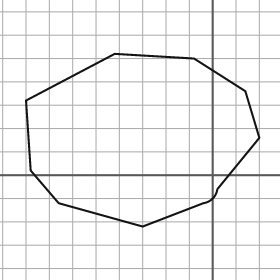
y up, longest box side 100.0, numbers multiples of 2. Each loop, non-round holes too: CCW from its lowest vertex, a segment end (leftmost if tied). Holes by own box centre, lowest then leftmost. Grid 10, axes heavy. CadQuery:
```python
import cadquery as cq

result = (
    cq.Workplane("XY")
    .moveTo(-30.0, -22.0)
    .lineTo(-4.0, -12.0)
    .threePointArc((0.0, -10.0), (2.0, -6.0))
    .lineTo(20.0, 16.0)
    .lineTo(14.0, 36.0)
    .lineTo(-8.0, 50.0)
    .lineTo(-42.0, 52.0)
    .lineTo(-80.0, 32.0)
    .lineTo(-78.0, 2.0)
    .lineTo(-66.0, -12.0)
    .close()
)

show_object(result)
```